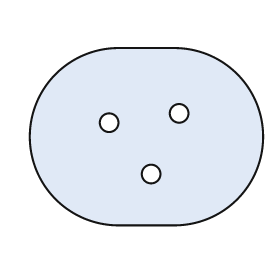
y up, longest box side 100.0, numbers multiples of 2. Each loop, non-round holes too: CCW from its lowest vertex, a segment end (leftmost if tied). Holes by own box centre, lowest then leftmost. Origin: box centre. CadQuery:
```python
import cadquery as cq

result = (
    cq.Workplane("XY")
    .moveTo(-12.0, -38.0)
    .lineTo(12.0, -38.0)
    .threePointArc((50.0, 0.0), (12.0, 38.0))
    .lineTo(-12.0, 38.0)
    .threePointArc((-50.0, 0.0), (-12.0, -38.0))
    .close()
    .moveTo(2.0, -16.0)
    .circle(4.0)
    .moveTo(-16.0, 6.0)
    .circle(4.0)
    .moveTo(14.0, 10.0)
    .circle(4.0)
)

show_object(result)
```